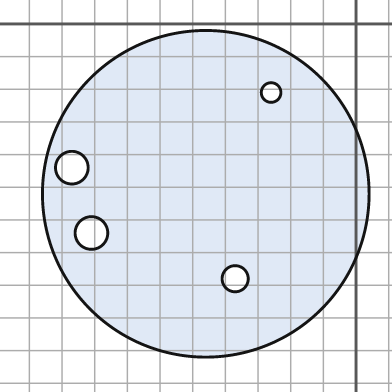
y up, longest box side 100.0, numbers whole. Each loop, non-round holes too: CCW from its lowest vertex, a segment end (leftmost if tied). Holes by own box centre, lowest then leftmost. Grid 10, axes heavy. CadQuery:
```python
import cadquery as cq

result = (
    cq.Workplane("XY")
    .moveTo(-46.0, -52.0)
    .circle(50.0)
    .moveTo(-37.0, -78.0)
    .circle(4.0)
    .moveTo(-81.0, -64.0)
    .circle(5.0)
    .moveTo(-87.0, -44.0)
    .circle(5.0)
    .moveTo(-26.0, -21.0)
    .circle(3.0)
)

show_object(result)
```